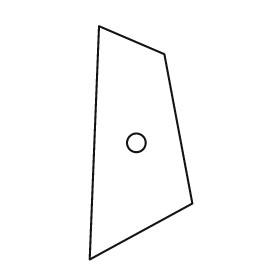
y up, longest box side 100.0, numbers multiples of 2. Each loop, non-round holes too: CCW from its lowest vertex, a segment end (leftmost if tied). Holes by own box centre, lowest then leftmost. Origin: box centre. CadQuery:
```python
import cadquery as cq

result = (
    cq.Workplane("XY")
    .moveTo(-22.0, -50.0)
    .lineTo(22.0, -26.0)
    .lineTo(10.0, 38.0)
    .lineTo(-18.0, 50.0)
    .close()
    .moveTo(-2.0, 0.0)
    .circle(4.0)
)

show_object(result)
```